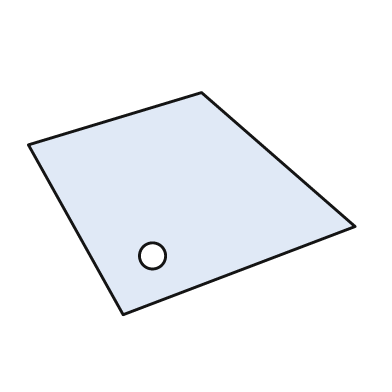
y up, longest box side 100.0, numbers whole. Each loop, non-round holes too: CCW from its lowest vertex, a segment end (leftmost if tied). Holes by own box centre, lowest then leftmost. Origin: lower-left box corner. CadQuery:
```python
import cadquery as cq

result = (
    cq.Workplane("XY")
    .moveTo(29.0, 0.0)
    .lineTo(100.0, 27.0)
    .lineTo(53.0, 68.0)
    .lineTo(0.0, 52.0)
    .close()
    .moveTo(38.0, 18.0)
    .circle(4.0)
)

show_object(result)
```